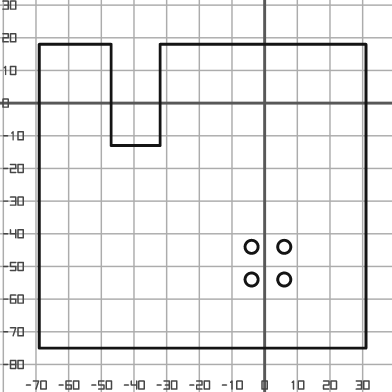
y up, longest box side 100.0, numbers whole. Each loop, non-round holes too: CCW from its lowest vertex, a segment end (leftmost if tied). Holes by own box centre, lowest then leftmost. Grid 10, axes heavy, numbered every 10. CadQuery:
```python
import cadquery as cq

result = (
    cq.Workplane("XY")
    .moveTo(-69.0, -75.0)
    .lineTo(31.0, -75.0)
    .lineTo(31.0, 18.0)
    .lineTo(-32.0, 18.0)
    .lineTo(-32.0, -13.0)
    .lineTo(-47.0, -13.0)
    .lineTo(-47.0, 18.0)
    .lineTo(-69.0, 18.0)
    .close()
    .moveTo(-4.0, -54.0)
    .circle(2.0)
    .moveTo(6.0, -54.0)
    .circle(2.0)
    .moveTo(-4.0, -44.0)
    .circle(2.0)
    .moveTo(6.0, -44.0)
    .circle(2.0)
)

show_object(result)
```